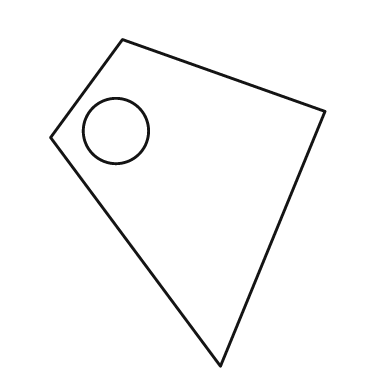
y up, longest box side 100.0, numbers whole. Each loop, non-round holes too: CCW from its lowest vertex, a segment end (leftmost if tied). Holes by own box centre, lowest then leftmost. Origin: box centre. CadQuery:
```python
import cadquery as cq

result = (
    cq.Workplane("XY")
    .moveTo(10.0, -50.0)
    .lineTo(42.0, 28.0)
    .lineTo(-20.0, 50.0)
    .lineTo(-42.0, 20.0)
    .close()
    .moveTo(-22.0, 22.0)
    .circle(10.0)
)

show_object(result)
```